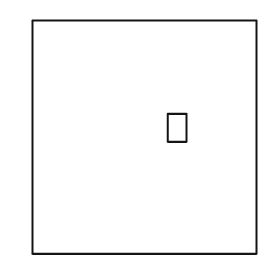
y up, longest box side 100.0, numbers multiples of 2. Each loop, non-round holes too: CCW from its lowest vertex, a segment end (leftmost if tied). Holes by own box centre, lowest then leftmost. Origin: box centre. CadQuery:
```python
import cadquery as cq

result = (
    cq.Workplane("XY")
    .moveTo(-48.0, -50.0)
    .lineTo(48.0, -50.0)
    .lineTo(48.0, 50.0)
    .lineTo(-48.0, 50.0)
    .close()
    .moveTo(10.0, -2.0)
    .lineTo(18.0, -2.0)
    .lineTo(18.0, 10.0)
    .lineTo(10.0, 10.0)
    .close()
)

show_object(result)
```